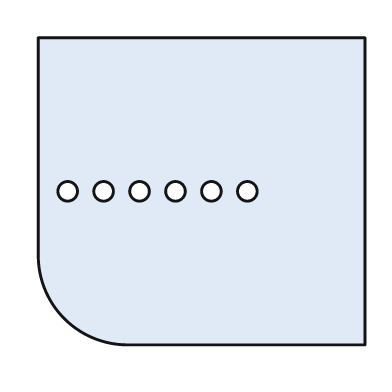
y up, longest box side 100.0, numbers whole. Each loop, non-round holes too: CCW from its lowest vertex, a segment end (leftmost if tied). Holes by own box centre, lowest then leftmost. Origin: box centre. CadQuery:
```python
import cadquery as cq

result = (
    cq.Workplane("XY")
    .moveTo(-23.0, -47.0)
    .lineTo(50.0, -47.0)
    .lineTo(50.0, 47.0)
    .lineTo(-50.0, 47.0)
    .lineTo(-50.0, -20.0)
    .threePointArc((-42.0, -39.0), (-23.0, -47.0))
    .close()
    .moveTo(-41.0, 0.0)
    .circle(3.0)
    .moveTo(-30.0, 0.0)
    .circle(3.0)
    .moveTo(-19.0, 0.0)
    .circle(3.0)
    .moveTo(-8.0, 0.0)
    .circle(3.0)
    .moveTo(3.0, 0.0)
    .circle(3.0)
    .moveTo(14.0, 0.0)
    .circle(3.0)
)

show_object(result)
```